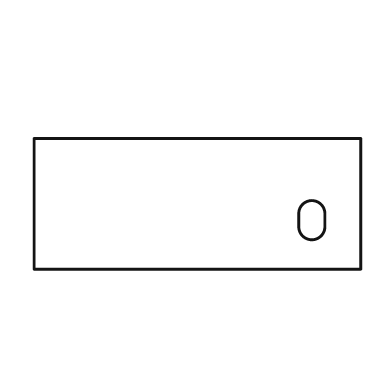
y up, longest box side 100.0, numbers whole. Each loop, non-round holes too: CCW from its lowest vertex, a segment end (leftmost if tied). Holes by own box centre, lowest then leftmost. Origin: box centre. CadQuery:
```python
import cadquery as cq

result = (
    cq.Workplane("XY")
    .moveTo(-50.0, -20.0)
    .lineTo(50.0, -20.0)
    .lineTo(50.0, 20.0)
    .lineTo(-50.0, 20.0)
    .close()
    .moveTo(31.0, -7.0)
    .threePointArc((35.0, -11.0), (39.0, -7.0))
    .lineTo(39.0, -3.0)
    .threePointArc((35.0, 1.0), (31.0, -3.0))
    .close()
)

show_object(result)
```